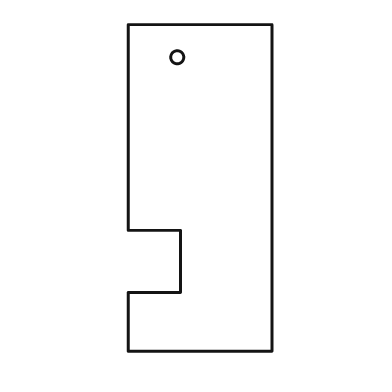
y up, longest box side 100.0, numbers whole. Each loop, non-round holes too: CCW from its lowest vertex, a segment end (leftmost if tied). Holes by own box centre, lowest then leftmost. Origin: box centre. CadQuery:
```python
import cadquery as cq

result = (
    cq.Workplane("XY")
    .moveTo(-22.0, -50.0)
    .lineTo(22.0, -50.0)
    .lineTo(22.0, 50.0)
    .lineTo(-22.0, 50.0)
    .lineTo(-22.0, -13.0)
    .lineTo(-6.0, -13.0)
    .lineTo(-6.0, -32.0)
    .lineTo(-22.0, -32.0)
    .close()
    .moveTo(-7.0, 40.0)
    .circle(2.0)
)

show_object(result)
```